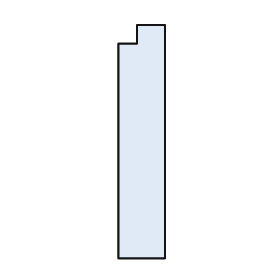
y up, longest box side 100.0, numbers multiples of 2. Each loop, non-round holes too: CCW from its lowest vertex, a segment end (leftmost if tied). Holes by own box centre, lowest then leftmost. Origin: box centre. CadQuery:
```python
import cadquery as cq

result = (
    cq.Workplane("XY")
    .moveTo(-10.0, -50.0)
    .lineTo(10.0, -50.0)
    .lineTo(10.0, 50.0)
    .lineTo(-2.0, 50.0)
    .lineTo(-2.0, 42.0)
    .lineTo(-10.0, 42.0)
    .close()
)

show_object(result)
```